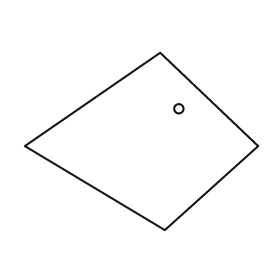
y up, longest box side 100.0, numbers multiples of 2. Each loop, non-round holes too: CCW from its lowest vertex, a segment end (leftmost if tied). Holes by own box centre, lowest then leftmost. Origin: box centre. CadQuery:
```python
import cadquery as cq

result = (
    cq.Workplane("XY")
    .moveTo(10.0, -38.0)
    .lineTo(50.0, -2.0)
    .lineTo(8.0, 38.0)
    .lineTo(-50.0, -2.0)
    .close()
    .moveTo(16.0, 14.0)
    .circle(2.0)
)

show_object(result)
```